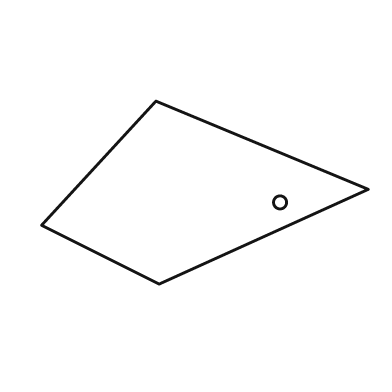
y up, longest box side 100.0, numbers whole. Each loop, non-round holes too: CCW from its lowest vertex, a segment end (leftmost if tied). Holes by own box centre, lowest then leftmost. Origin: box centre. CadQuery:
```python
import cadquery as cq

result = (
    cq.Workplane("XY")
    .moveTo(-14.0, -28.0)
    .lineTo(50.0, 1.0)
    .lineTo(-15.0, 28.0)
    .lineTo(-50.0, -10.0)
    .close()
    .moveTo(23.0, -3.0)
    .circle(2.0)
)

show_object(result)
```